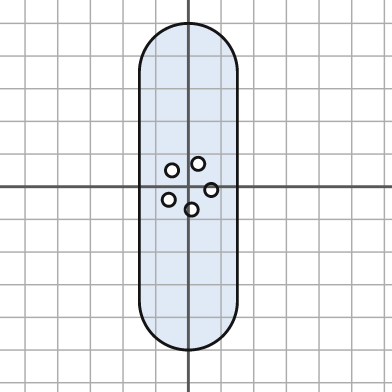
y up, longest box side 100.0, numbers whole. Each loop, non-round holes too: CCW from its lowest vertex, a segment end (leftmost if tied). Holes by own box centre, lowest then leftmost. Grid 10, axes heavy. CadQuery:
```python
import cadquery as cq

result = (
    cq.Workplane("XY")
    .moveTo(-15.0, -35.0)
    .threePointArc((0.0, -50.0), (15.0, -35.0))
    .lineTo(15.0, 35.0)
    .threePointArc((0.0, 50.0), (-15.0, 35.0))
    .close()
    .moveTo(1.0, -7.0)
    .circle(2.0)
    .moveTo(-6.0, -4.0)
    .circle(2.0)
    .moveTo(7.0, -1.0)
    .circle(2.0)
    .moveTo(-5.0, 5.0)
    .circle(2.0)
    .moveTo(3.0, 7.0)
    .circle(2.0)
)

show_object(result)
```